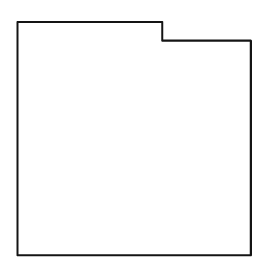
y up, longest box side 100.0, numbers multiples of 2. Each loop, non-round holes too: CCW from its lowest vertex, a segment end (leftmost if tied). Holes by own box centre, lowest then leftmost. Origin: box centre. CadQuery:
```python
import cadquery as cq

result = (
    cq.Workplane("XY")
    .moveTo(-50.0, -50.0)
    .lineTo(50.0, -50.0)
    .lineTo(50.0, 42.0)
    .lineTo(12.0, 42.0)
    .lineTo(12.0, 50.0)
    .lineTo(-50.0, 50.0)
    .close()
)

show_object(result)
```